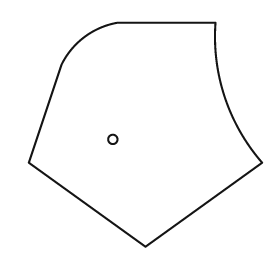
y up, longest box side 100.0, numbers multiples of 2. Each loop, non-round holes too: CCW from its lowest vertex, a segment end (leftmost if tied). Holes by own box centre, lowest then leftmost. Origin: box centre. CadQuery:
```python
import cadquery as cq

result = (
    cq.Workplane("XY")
    .moveTo(0.0, -48.0)
    .lineTo(50.0, -12.0)
    .threePointArc((34.0, 16.0), (30.0, 48.0))
    .lineTo(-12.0, 48.0)
    .threePointArc((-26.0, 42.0), (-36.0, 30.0))
    .lineTo(-50.0, -12.0)
    .close()
    .moveTo(-14.0, -2.0)
    .circle(2.0)
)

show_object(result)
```